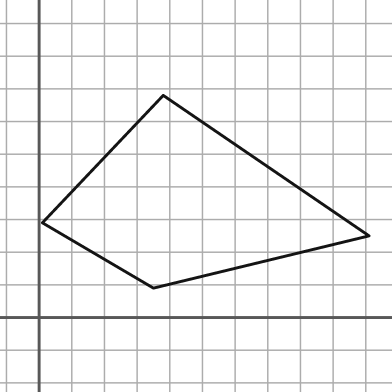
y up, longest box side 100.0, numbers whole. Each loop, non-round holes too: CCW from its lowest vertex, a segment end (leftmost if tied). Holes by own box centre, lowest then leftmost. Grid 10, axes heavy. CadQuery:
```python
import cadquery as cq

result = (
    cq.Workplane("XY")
    .moveTo(35.0, 9.0)
    .lineTo(101.0, 25.0)
    .lineTo(38.0, 68.0)
    .lineTo(1.0, 29.0)
    .close()
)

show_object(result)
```